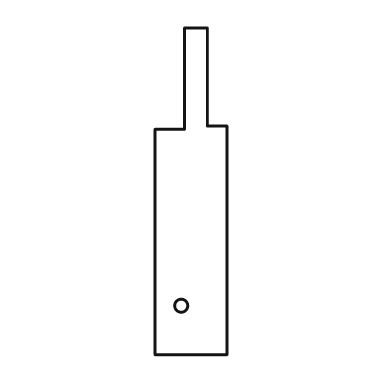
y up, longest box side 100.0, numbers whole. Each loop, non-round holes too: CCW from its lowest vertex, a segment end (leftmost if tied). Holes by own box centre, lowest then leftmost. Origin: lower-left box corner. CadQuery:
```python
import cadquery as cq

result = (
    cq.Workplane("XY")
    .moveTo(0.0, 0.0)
    .lineTo(22.0, 0.0)
    .lineTo(22.0, 70.0)
    .lineTo(16.0, 70.0)
    .lineTo(16.0, 100.0)
    .lineTo(9.0, 100.0)
    .lineTo(9.0, 69.0)
    .lineTo(0.0, 69.0)
    .close()
    .moveTo(8.0, 15.0)
    .circle(2.0)
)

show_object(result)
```